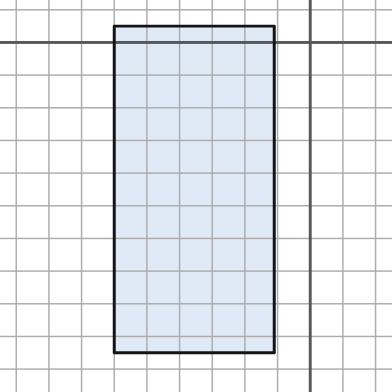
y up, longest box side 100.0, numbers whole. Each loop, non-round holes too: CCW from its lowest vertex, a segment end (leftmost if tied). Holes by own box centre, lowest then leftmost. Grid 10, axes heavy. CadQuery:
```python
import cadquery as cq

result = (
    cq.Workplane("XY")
    .moveTo(-60.0, -95.0)
    .lineTo(-11.0, -95.0)
    .lineTo(-11.0, 5.0)
    .lineTo(-60.0, 5.0)
    .close()
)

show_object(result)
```